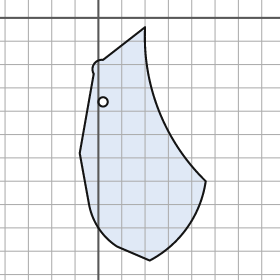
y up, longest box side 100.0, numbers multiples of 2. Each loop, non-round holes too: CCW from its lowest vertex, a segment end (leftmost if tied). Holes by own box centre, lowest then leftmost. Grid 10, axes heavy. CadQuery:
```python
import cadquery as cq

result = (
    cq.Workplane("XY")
    .moveTo(22.0, -104.0)
    .threePointArc((38.0, -90.0), (46.0, -70.0))
    .threePointArc((26.0, -40.0), (20.0, -4.0))
    .lineTo(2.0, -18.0)
    .threePointArc((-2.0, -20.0), (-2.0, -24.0))
    .lineTo(-8.0, -58.0)
    .lineTo(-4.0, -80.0)
    .threePointArc((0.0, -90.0), (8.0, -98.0))
    .close()
    .moveTo(2.0, -36.0)
    .circle(2.0)
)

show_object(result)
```